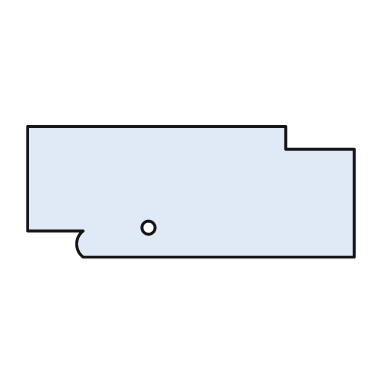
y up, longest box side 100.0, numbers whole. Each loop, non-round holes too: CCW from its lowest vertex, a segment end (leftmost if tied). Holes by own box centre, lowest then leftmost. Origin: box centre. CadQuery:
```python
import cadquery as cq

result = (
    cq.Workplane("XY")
    .moveTo(-33.0, -20.0)
    .lineTo(50.0, -20.0)
    .lineTo(50.0, 13.0)
    .lineTo(29.0, 13.0)
    .lineTo(29.0, 20.0)
    .lineTo(-50.0, 20.0)
    .lineTo(-50.0, -12.0)
    .lineTo(-33.0, -12.0)
    .threePointArc((-35.0, -16.0), (-33.0, -20.0))
    .close()
    .moveTo(-13.0, -11.0)
    .circle(2.0)
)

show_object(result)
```